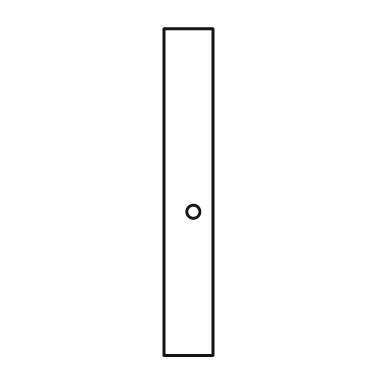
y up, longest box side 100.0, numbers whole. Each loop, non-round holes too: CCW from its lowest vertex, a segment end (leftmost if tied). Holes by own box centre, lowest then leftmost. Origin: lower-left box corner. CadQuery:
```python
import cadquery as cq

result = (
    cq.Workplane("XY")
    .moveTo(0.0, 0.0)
    .lineTo(15.0, 0.0)
    .lineTo(15.0, 100.0)
    .lineTo(0.0, 100.0)
    .close()
    .moveTo(9.0, 44.0)
    .circle(2.0)
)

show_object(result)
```